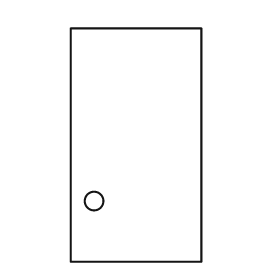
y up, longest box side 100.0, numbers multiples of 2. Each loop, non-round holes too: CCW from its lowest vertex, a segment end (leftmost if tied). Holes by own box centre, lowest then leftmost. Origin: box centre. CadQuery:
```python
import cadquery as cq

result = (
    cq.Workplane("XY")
    .moveTo(-28.0, -50.0)
    .lineTo(28.0, -50.0)
    .lineTo(28.0, 50.0)
    .lineTo(-28.0, 50.0)
    .close()
    .moveTo(-18.0, -24.0)
    .circle(4.0)
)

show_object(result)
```